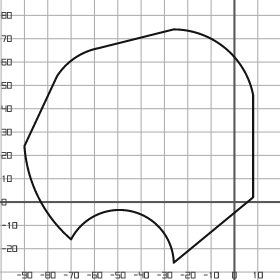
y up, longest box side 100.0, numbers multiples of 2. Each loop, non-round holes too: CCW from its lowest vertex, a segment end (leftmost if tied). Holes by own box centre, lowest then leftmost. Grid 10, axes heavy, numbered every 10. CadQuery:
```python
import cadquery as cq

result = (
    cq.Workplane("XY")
    .moveTo(-26.0, -26.0)
    .lineTo(8.0, 2.0)
    .lineTo(8.0, 46.0)
    .threePointArc((-4.0, 66.0), (-26.0, 74.0))
    .lineTo(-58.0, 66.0)
    .threePointArc((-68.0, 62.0), (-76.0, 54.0))
    .lineTo(-90.0, 24.0)
    .threePointArc((-84.0, 2.0), (-70.0, -16.0))
    .threePointArc((-44.0, -4.0), (-26.0, -26.0))
    .close()
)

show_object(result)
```